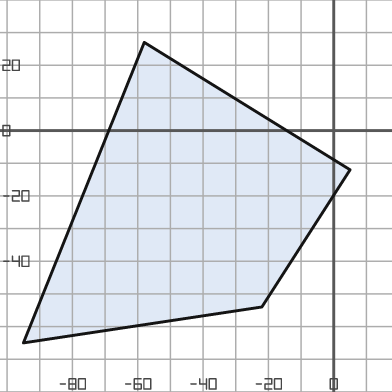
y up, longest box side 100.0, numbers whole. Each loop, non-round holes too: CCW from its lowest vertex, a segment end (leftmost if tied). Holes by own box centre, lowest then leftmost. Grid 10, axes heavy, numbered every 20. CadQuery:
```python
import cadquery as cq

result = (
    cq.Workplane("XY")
    .moveTo(-95.0, -65.0)
    .lineTo(-22.0, -54.0)
    .lineTo(5.0, -12.0)
    .lineTo(-58.0, 27.0)
    .close()
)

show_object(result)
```